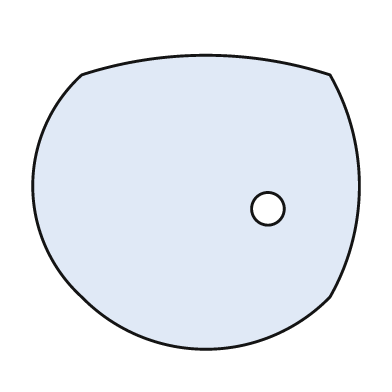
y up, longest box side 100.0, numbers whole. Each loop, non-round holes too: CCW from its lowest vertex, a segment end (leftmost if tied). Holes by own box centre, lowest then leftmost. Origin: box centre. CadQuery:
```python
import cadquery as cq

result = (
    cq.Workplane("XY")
    .moveTo(-35.0, -29.0)
    .threePointArc((3.0, -45.0), (41.0, -29.0))
    .threePointArc((50.0, 5.0), (41.0, 39.0))
    .threePointArc((3.0, 45.0), (-35.0, 39.0))
    .threePointArc((-50.0, 5.0), (-35.0, -29.0))
    .close()
    .moveTo(22.0, -2.0)
    .circle(5.0)
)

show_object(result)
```